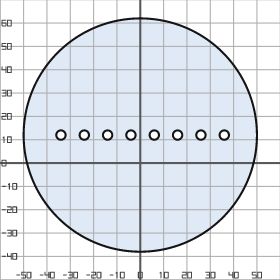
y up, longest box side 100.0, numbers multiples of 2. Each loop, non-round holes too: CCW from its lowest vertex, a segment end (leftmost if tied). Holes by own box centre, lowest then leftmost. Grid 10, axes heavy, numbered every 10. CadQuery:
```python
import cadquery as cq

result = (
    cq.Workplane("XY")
    .moveTo(0.0, 12.0)
    .circle(50.0)
    .moveTo(-34.0, 12.0)
    .circle(2.0)
    .moveTo(-24.0, 12.0)
    .circle(2.0)
    .moveTo(-14.0, 12.0)
    .circle(2.0)
    .moveTo(-4.0, 12.0)
    .circle(2.0)
    .moveTo(6.0, 12.0)
    .circle(2.0)
    .moveTo(16.0, 12.0)
    .circle(2.0)
    .moveTo(26.0, 12.0)
    .circle(2.0)
    .moveTo(36.0, 12.0)
    .circle(2.0)
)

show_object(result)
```